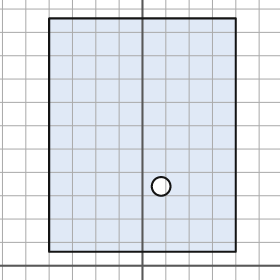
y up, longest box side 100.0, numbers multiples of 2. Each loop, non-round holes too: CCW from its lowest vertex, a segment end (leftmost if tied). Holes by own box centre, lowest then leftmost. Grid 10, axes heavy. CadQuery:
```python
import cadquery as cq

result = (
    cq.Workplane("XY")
    .moveTo(-40.0, 6.0)
    .lineTo(40.0, 6.0)
    .lineTo(40.0, 106.0)
    .lineTo(-40.0, 106.0)
    .close()
    .moveTo(8.0, 34.0)
    .circle(4.0)
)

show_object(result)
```